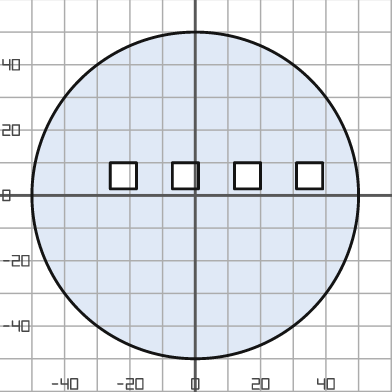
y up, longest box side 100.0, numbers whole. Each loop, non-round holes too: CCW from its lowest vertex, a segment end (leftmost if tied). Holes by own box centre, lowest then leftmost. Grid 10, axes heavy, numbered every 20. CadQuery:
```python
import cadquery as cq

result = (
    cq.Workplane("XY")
    .moveTo(0.0, 0.0)
    .circle(50.0)
    .moveTo(-26.0, 2.0)
    .lineTo(-18.0, 2.0)
    .lineTo(-18.0, 10.0)
    .lineTo(-26.0, 10.0)
    .close()
    .moveTo(-7.0, 2.0)
    .lineTo(1.0, 2.0)
    .lineTo(1.0, 10.0)
    .lineTo(-7.0, 10.0)
    .close()
    .moveTo(12.0, 2.0)
    .lineTo(20.0, 2.0)
    .lineTo(20.0, 10.0)
    .lineTo(12.0, 10.0)
    .close()
    .moveTo(31.0, 2.0)
    .lineTo(39.0, 2.0)
    .lineTo(39.0, 10.0)
    .lineTo(31.0, 10.0)
    .close()
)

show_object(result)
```